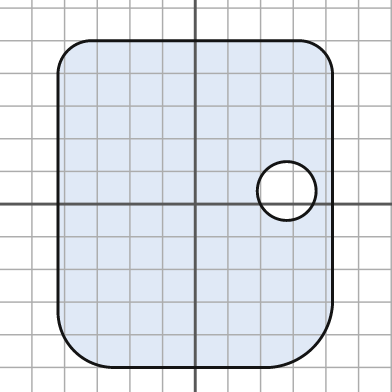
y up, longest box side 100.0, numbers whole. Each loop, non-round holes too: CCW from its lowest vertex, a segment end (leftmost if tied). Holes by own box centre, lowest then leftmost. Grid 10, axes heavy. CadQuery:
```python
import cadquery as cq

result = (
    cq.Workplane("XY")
    .moveTo(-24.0, -50.0)
    .lineTo(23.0, -50.0)
    .threePointArc((36.0, -44.0), (42.0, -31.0))
    .lineTo(42.0, 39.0)
    .threePointArc((39.0, 47.0), (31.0, 50.0))
    .lineTo(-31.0, 50.0)
    .threePointArc((-39.0, 47.0), (-42.0, 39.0))
    .lineTo(-42.0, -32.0)
    .threePointArc((-37.0, -45.0), (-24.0, -50.0))
    .close()
    .moveTo(28.0, 4.0)
    .circle(9.0)
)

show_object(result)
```